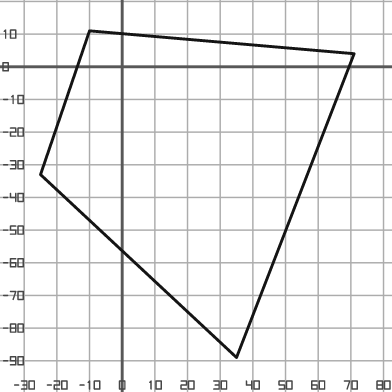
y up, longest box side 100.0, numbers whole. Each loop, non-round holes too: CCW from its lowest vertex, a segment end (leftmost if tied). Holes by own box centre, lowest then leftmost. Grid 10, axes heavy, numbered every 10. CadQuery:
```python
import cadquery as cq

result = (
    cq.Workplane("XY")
    .moveTo(35.0, -89.0)
    .lineTo(71.0, 4.0)
    .lineTo(-10.0, 11.0)
    .lineTo(-25.0, -33.0)
    .close()
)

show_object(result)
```